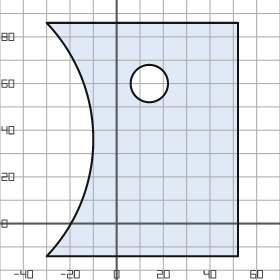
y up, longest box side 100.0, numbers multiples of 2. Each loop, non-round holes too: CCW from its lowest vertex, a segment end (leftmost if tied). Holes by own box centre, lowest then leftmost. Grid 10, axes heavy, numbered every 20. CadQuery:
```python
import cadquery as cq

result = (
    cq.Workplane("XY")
    .moveTo(-30.0, -14.0)
    .lineTo(52.0, -14.0)
    .lineTo(52.0, 86.0)
    .lineTo(-30.0, 86.0)
    .threePointArc((-10.0, 36.0), (-30.0, -14.0))
    .close()
    .moveTo(14.0, 60.0)
    .circle(8.0)
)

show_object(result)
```